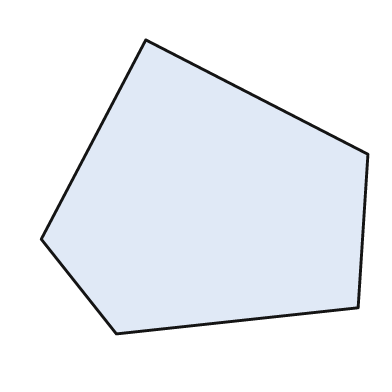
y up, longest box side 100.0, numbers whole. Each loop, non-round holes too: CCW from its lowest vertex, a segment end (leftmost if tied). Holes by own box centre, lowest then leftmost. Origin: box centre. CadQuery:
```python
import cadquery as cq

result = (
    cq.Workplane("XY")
    .moveTo(-27.0, -45.0)
    .lineTo(47.0, -37.0)
    .lineTo(50.0, 10.0)
    .lineTo(-18.0, 45.0)
    .lineTo(-50.0, -16.0)
    .close()
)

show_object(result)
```